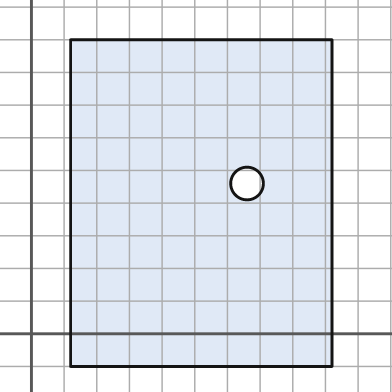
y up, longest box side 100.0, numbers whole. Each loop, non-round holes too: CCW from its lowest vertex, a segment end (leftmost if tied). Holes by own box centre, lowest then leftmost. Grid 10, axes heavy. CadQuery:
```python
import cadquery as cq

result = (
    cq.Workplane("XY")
    .moveTo(12.0, -10.0)
    .lineTo(92.0, -10.0)
    .lineTo(92.0, 90.0)
    .lineTo(12.0, 90.0)
    .close()
    .moveTo(66.0, 46.0)
    .circle(5.0)
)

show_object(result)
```